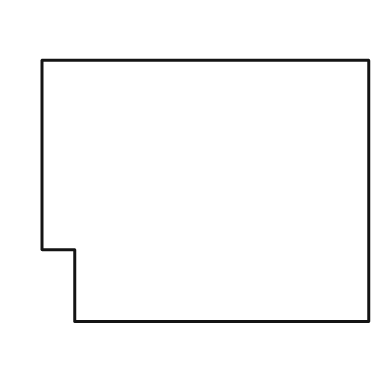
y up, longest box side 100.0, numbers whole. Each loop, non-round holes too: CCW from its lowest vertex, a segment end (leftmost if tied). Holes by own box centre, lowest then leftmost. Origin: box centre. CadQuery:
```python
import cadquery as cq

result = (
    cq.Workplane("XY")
    .moveTo(-40.0, -40.0)
    .lineTo(50.0, -40.0)
    .lineTo(50.0, 40.0)
    .lineTo(-50.0, 40.0)
    .lineTo(-50.0, -18.0)
    .lineTo(-40.0, -18.0)
    .close()
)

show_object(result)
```